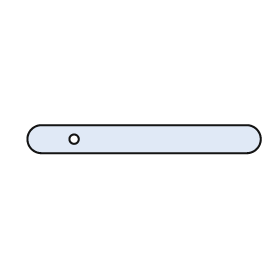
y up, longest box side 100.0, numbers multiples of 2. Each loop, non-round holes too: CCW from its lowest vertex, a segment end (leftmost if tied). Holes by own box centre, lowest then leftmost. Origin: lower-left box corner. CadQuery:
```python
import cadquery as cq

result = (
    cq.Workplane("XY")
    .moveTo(6.0, 0.0)
    .lineTo(94.0, 0.0)
    .threePointArc((100.0, 6.0), (94.0, 12.0))
    .lineTo(6.0, 12.0)
    .threePointArc((0.0, 6.0), (6.0, 0.0))
    .close()
    .moveTo(20.0, 6.0)
    .circle(2.0)
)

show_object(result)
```